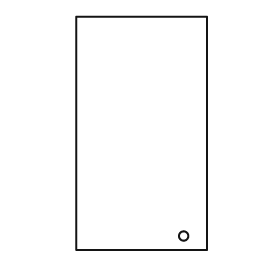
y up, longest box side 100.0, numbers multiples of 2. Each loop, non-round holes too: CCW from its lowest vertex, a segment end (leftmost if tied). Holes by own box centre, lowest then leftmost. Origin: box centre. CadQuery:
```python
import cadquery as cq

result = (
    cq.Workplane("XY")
    .moveTo(-28.0, -50.0)
    .lineTo(28.0, -50.0)
    .lineTo(28.0, 50.0)
    .lineTo(-28.0, 50.0)
    .close()
    .moveTo(18.0, -44.0)
    .circle(2.0)
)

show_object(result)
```